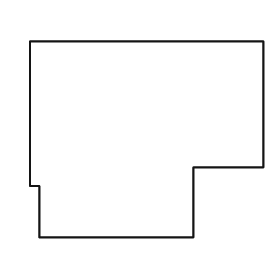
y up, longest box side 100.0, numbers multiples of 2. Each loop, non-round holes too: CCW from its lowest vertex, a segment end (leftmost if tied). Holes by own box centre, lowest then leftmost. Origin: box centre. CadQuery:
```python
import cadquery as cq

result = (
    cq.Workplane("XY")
    .moveTo(-46.0, -42.0)
    .lineTo(20.0, -42.0)
    .lineTo(20.0, -12.0)
    .lineTo(50.0, -12.0)
    .lineTo(50.0, 42.0)
    .lineTo(-50.0, 42.0)
    .lineTo(-50.0, -20.0)
    .lineTo(-46.0, -20.0)
    .close()
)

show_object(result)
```